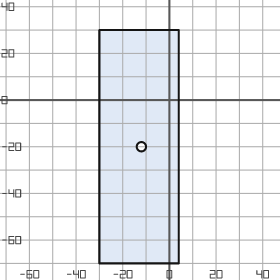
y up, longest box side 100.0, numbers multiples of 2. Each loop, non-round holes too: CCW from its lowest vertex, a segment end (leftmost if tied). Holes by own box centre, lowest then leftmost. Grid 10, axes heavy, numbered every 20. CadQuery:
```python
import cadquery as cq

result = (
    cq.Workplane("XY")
    .moveTo(-30.0, -70.0)
    .lineTo(4.0, -70.0)
    .lineTo(4.0, 30.0)
    .lineTo(-30.0, 30.0)
    .close()
    .moveTo(-12.0, -20.0)
    .circle(2.0)
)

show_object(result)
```